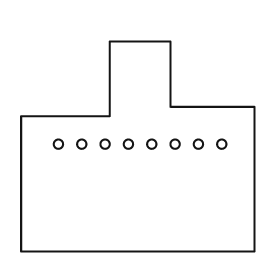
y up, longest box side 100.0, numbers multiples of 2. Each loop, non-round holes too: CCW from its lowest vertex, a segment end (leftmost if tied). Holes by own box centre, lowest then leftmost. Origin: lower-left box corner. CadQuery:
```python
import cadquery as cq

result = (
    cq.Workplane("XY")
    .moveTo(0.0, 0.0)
    .lineTo(100.0, 0.0)
    .lineTo(100.0, 62.0)
    .lineTo(64.0, 62.0)
    .lineTo(64.0, 90.0)
    .lineTo(38.0, 90.0)
    .lineTo(38.0, 58.0)
    .lineTo(0.0, 58.0)
    .close()
    .moveTo(16.0, 46.0)
    .circle(2.0)
    .moveTo(26.0, 46.0)
    .circle(2.0)
    .moveTo(36.0, 46.0)
    .circle(2.0)
    .moveTo(46.0, 46.0)
    .circle(2.0)
    .moveTo(56.0, 46.0)
    .circle(2.0)
    .moveTo(66.0, 46.0)
    .circle(2.0)
    .moveTo(76.0, 46.0)
    .circle(2.0)
    .moveTo(86.0, 46.0)
    .circle(2.0)
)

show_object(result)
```